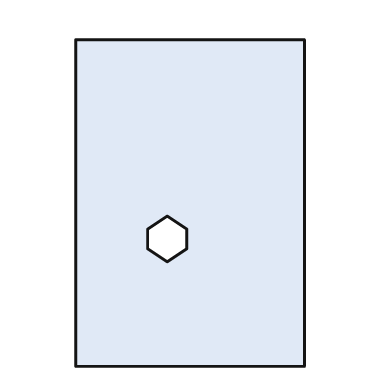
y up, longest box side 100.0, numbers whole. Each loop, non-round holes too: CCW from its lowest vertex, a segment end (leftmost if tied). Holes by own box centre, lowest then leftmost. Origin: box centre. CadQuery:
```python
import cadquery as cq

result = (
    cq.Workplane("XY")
    .moveTo(-35.0, -50.0)
    .lineTo(35.0, -50.0)
    .lineTo(35.0, 50.0)
    .lineTo(-35.0, 50.0)
    .close()
    .moveTo(-7.0, -18.0)
    .lineTo(-1.0, -14.0)
    .lineTo(-1.0, -8.0)
    .lineTo(-7.0, -4.0)
    .lineTo(-13.0, -8.0)
    .lineTo(-13.0, -14.0)
    .close()
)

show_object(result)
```